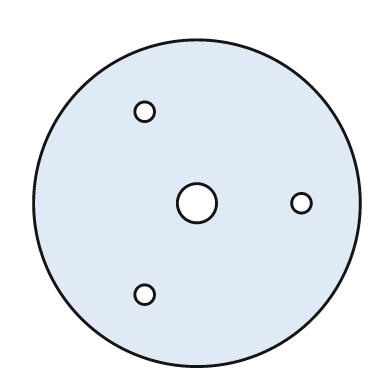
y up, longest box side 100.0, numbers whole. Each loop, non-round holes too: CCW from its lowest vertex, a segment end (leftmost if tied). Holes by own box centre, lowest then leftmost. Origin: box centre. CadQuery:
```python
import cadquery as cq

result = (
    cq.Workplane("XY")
    .moveTo(0.0, 0.0)
    .circle(50.0)
    .moveTo(-16.0, -28.0)
    .circle(3.0)
    .moveTo(0.0, 0.0)
    .circle(6.0)
    .moveTo(32.0, 0.0)
    .circle(3.0)
    .moveTo(-16.0, 28.0)
    .circle(3.0)
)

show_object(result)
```